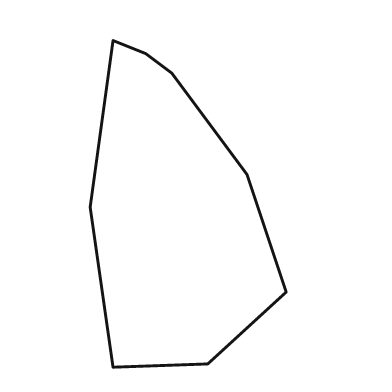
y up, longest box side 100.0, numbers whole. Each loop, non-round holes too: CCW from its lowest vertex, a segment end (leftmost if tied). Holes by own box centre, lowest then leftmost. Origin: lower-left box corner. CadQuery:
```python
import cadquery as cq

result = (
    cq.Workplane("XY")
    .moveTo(7.0, 0.0)
    .lineTo(36.0, 1.0)
    .lineTo(60.0, 23.0)
    .lineTo(48.0, 59.0)
    .lineTo(25.0, 90.0)
    .lineTo(17.0, 96.0)
    .lineTo(7.0, 100.0)
    .lineTo(0.0, 49.0)
    .close()
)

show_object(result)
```